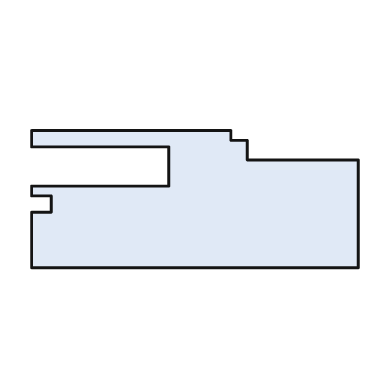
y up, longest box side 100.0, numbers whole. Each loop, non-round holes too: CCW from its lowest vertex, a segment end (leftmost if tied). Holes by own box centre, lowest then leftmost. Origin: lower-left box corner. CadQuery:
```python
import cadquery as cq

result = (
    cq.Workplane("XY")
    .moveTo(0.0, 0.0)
    .lineTo(100.0, 0.0)
    .lineTo(100.0, 33.0)
    .lineTo(66.0, 33.0)
    .lineTo(66.0, 39.0)
    .lineTo(61.0, 39.0)
    .lineTo(61.0, 42.0)
    .lineTo(0.0, 42.0)
    .lineTo(0.0, 37.0)
    .lineTo(42.0, 37.0)
    .lineTo(42.0, 25.0)
    .lineTo(0.0, 25.0)
    .lineTo(0.0, 22.0)
    .lineTo(6.0, 22.0)
    .lineTo(6.0, 17.0)
    .lineTo(0.0, 17.0)
    .close()
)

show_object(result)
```